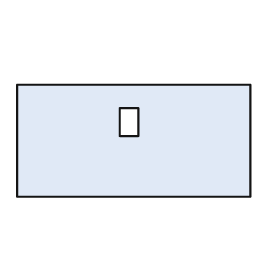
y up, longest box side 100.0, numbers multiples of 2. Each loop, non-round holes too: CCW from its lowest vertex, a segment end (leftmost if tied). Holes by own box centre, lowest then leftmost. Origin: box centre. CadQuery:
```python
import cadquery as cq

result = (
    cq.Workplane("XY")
    .moveTo(-50.0, -24.0)
    .lineTo(50.0, -24.0)
    .lineTo(50.0, 24.0)
    .lineTo(-50.0, 24.0)
    .close()
    .moveTo(-6.0, 2.0)
    .lineTo(2.0, 2.0)
    .lineTo(2.0, 14.0)
    .lineTo(-6.0, 14.0)
    .close()
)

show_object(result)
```